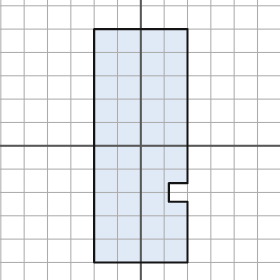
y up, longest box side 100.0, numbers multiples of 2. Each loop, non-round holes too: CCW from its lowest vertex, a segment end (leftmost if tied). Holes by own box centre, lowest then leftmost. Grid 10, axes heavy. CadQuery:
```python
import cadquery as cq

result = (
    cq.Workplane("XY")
    .moveTo(-20.0, -50.0)
    .lineTo(20.0, -50.0)
    .lineTo(20.0, -24.0)
    .lineTo(12.0, -24.0)
    .lineTo(12.0, -16.0)
    .lineTo(20.0, -16.0)
    .lineTo(20.0, 50.0)
    .lineTo(-20.0, 50.0)
    .close()
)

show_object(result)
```